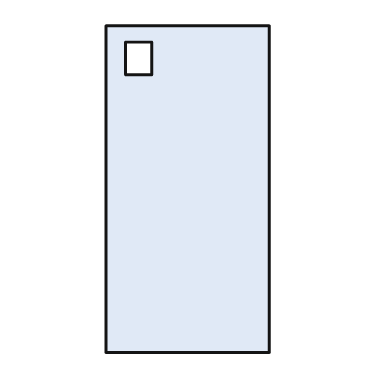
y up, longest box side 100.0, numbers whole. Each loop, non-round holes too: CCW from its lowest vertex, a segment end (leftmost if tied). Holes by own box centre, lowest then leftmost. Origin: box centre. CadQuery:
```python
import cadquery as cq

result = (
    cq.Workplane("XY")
    .moveTo(-25.0, -50.0)
    .lineTo(25.0, -50.0)
    .lineTo(25.0, 50.0)
    .lineTo(-25.0, 50.0)
    .close()
    .moveTo(-19.0, 35.0)
    .lineTo(-11.0, 35.0)
    .lineTo(-11.0, 45.0)
    .lineTo(-19.0, 45.0)
    .close()
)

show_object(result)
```